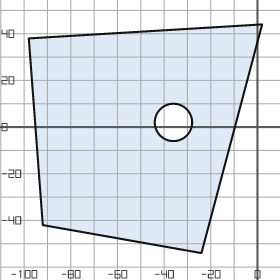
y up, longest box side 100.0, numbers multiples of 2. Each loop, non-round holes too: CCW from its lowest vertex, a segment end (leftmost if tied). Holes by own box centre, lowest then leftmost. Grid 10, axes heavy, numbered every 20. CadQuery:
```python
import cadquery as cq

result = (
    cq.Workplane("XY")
    .moveTo(-24.0, -54.0)
    .lineTo(2.0, 44.0)
    .lineTo(-98.0, 38.0)
    .lineTo(-92.0, -42.0)
    .close()
    .moveTo(-36.0, 2.0)
    .circle(8.0)
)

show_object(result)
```